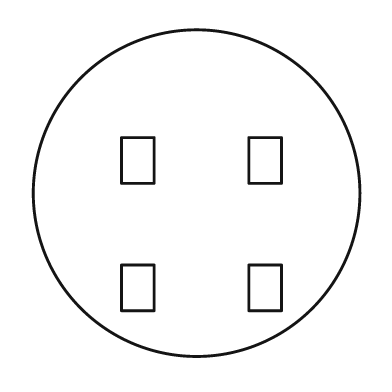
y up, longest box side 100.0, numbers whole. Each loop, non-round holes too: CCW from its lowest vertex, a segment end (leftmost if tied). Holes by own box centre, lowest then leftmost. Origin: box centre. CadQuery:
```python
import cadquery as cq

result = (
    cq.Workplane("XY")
    .moveTo(0.0, 0.0)
    .circle(50.0)
    .moveTo(-23.0, -36.0)
    .lineTo(-13.0, -36.0)
    .lineTo(-13.0, -22.0)
    .lineTo(-23.0, -22.0)
    .close()
    .moveTo(16.0, -36.0)
    .lineTo(26.0, -36.0)
    .lineTo(26.0, -22.0)
    .lineTo(16.0, -22.0)
    .close()
    .moveTo(-23.0, 3.0)
    .lineTo(-13.0, 3.0)
    .lineTo(-13.0, 17.0)
    .lineTo(-23.0, 17.0)
    .close()
    .moveTo(16.0, 3.0)
    .lineTo(26.0, 3.0)
    .lineTo(26.0, 17.0)
    .lineTo(16.0, 17.0)
    .close()
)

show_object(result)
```